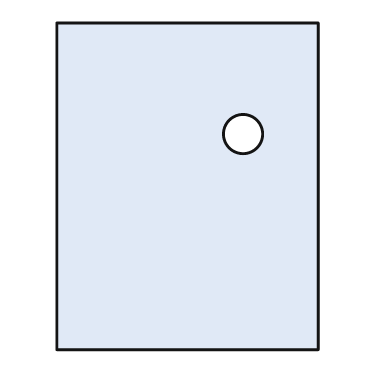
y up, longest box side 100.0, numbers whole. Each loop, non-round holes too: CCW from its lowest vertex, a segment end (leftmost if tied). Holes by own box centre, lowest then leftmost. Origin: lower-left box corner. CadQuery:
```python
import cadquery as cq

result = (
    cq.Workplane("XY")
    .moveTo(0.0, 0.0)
    .lineTo(80.0, 0.0)
    .lineTo(80.0, 100.0)
    .lineTo(0.0, 100.0)
    .close()
    .moveTo(57.0, 66.0)
    .circle(6.0)
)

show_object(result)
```